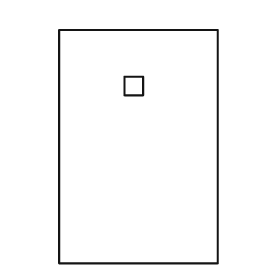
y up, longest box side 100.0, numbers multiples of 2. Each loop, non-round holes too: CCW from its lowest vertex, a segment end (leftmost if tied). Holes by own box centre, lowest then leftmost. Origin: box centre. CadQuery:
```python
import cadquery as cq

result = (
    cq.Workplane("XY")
    .moveTo(-34.0, -50.0)
    .lineTo(34.0, -50.0)
    .lineTo(34.0, 50.0)
    .lineTo(-34.0, 50.0)
    .close()
    .moveTo(-6.0, 22.0)
    .lineTo(2.0, 22.0)
    .lineTo(2.0, 30.0)
    .lineTo(-6.0, 30.0)
    .close()
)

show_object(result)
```